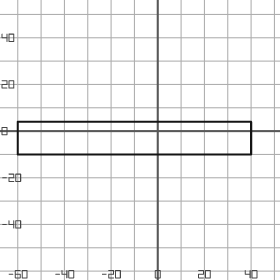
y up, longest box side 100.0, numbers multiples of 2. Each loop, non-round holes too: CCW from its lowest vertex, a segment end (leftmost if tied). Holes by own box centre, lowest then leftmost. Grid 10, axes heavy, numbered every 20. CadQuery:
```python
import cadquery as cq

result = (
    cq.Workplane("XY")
    .moveTo(-60.0, -10.0)
    .lineTo(40.0, -10.0)
    .lineTo(40.0, 4.0)
    .lineTo(-60.0, 4.0)
    .close()
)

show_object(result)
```